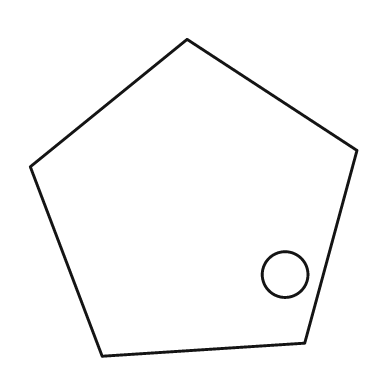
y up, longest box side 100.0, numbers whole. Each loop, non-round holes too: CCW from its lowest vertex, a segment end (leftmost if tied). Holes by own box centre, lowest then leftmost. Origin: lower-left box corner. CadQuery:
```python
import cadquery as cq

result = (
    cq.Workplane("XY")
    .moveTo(22.0, 0.0)
    .lineTo(84.0, 4.0)
    .lineTo(100.0, 63.0)
    .lineTo(48.0, 97.0)
    .lineTo(0.0, 58.0)
    .close()
    .moveTo(78.0, 25.0)
    .circle(7.0)
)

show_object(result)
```